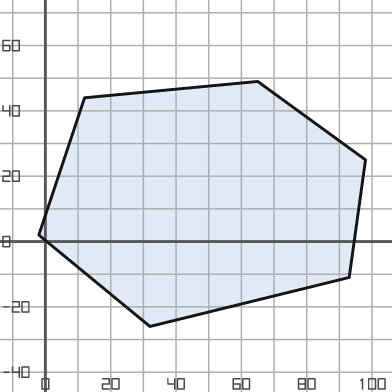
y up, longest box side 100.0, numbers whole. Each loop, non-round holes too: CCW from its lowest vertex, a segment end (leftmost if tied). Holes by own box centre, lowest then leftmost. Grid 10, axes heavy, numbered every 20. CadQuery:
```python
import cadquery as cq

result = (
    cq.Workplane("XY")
    .moveTo(32.0, -26.0)
    .lineTo(93.0, -11.0)
    .lineTo(98.0, 25.0)
    .lineTo(65.0, 49.0)
    .lineTo(12.0, 44.0)
    .lineTo(-2.0, 2.0)
    .close()
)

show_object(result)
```